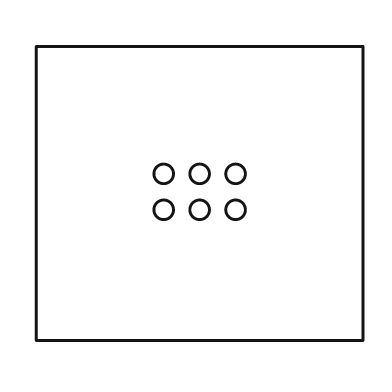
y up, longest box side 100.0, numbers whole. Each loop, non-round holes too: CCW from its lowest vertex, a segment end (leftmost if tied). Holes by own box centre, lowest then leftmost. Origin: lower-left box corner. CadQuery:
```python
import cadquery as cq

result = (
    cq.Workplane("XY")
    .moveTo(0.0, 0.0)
    .lineTo(100.0, 0.0)
    .lineTo(100.0, 90.0)
    .lineTo(0.0, 90.0)
    .close()
    .moveTo(39.0, 40.0)
    .circle(3.0)
    .moveTo(50.0, 40.0)
    .circle(3.0)
    .moveTo(61.0, 40.0)
    .circle(3.0)
    .moveTo(39.0, 51.0)
    .circle(3.0)
    .moveTo(50.0, 51.0)
    .circle(3.0)
    .moveTo(61.0, 51.0)
    .circle(3.0)
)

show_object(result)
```